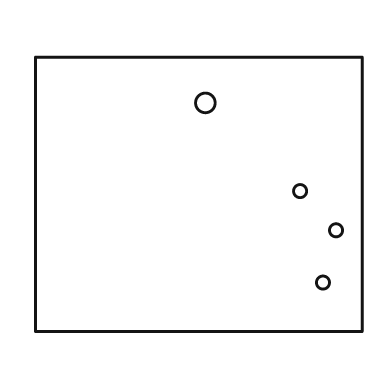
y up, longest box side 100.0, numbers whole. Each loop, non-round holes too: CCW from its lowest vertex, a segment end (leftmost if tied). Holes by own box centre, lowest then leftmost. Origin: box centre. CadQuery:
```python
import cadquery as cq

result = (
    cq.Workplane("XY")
    .moveTo(-50.0, -42.0)
    .lineTo(50.0, -42.0)
    .lineTo(50.0, 42.0)
    .lineTo(-50.0, 42.0)
    .close()
    .moveTo(38.0, -27.0)
    .circle(2.0)
    .moveTo(42.0, -11.0)
    .circle(2.0)
    .moveTo(31.0, 1.0)
    .circle(2.0)
    .moveTo(2.0, 28.0)
    .circle(3.0)
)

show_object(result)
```